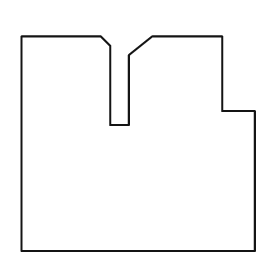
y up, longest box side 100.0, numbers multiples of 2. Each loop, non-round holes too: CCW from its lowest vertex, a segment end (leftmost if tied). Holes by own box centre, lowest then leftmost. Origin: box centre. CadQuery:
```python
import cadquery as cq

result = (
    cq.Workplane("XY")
    .moveTo(-50.0, -46.0)
    .lineTo(50.0, -46.0)
    .lineTo(50.0, 14.0)
    .lineTo(36.0, 14.0)
    .lineTo(36.0, 46.0)
    .lineTo(6.0, 46.0)
    .lineTo(-4.0, 38.0)
    .lineTo(-4.0, 8.0)
    .lineTo(-12.0, 8.0)
    .lineTo(-12.0, 42.0)
    .lineTo(-16.0, 46.0)
    .lineTo(-50.0, 46.0)
    .close()
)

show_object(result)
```